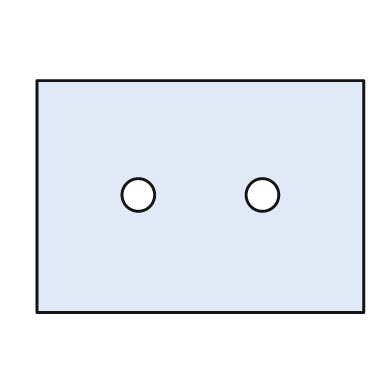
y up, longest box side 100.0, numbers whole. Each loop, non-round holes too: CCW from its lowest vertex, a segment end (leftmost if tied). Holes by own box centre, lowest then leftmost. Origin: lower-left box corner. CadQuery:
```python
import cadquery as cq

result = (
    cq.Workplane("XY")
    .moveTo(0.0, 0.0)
    .lineTo(100.0, 0.0)
    .lineTo(100.0, 71.0)
    .lineTo(0.0, 71.0)
    .close()
    .moveTo(31.0, 36.0)
    .circle(5.0)
    .moveTo(69.0, 36.0)
    .circle(5.0)
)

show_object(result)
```